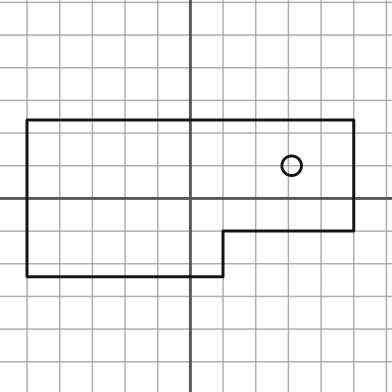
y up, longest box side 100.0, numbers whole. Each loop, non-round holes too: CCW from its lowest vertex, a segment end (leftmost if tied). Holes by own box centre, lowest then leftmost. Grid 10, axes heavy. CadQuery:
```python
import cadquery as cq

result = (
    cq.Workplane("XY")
    .moveTo(-50.0, -24.0)
    .lineTo(10.0, -24.0)
    .lineTo(10.0, -10.0)
    .lineTo(50.0, -10.0)
    .lineTo(50.0, 24.0)
    .lineTo(-50.0, 24.0)
    .close()
    .moveTo(31.0, 10.0)
    .circle(3.0)
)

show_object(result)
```